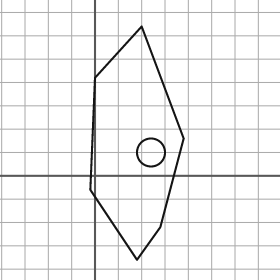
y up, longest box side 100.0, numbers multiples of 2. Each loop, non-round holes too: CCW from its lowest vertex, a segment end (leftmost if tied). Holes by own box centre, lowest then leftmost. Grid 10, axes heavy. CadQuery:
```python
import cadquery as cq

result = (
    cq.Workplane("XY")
    .moveTo(18.0, -36.0)
    .lineTo(28.0, -22.0)
    .lineTo(38.0, 16.0)
    .lineTo(20.0, 64.0)
    .lineTo(0.0, 42.0)
    .lineTo(-2.0, -6.0)
    .close()
    .moveTo(24.0, 10.0)
    .circle(6.0)
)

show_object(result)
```